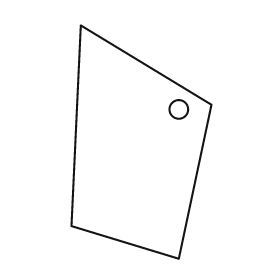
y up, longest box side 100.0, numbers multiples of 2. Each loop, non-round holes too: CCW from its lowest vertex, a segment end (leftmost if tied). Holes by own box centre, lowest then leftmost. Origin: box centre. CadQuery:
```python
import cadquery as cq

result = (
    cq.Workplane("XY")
    .moveTo(16.0, -50.0)
    .lineTo(30.0, 16.0)
    .lineTo(-26.0, 50.0)
    .lineTo(-30.0, -36.0)
    .close()
    .moveTo(16.0, 14.0)
    .circle(4.0)
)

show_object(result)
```